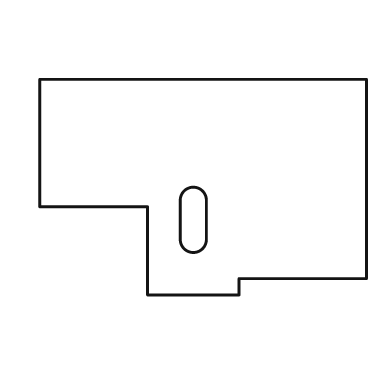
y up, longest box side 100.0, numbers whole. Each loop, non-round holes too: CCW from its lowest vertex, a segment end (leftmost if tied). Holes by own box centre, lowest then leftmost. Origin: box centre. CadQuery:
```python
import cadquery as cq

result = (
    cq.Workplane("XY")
    .moveTo(-17.0, -33.0)
    .lineTo(11.0, -33.0)
    .lineTo(11.0, -28.0)
    .lineTo(50.0, -28.0)
    .lineTo(50.0, 33.0)
    .lineTo(-50.0, 33.0)
    .lineTo(-50.0, -6.0)
    .lineTo(-17.0, -6.0)
    .close()
    .moveTo(-7.0, -16.0)
    .threePointArc((-3.0, -20.0), (1.0, -16.0))
    .lineTo(1.0, -4.0)
    .threePointArc((-3.0, 0.0), (-7.0, -4.0))
    .close()
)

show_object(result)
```